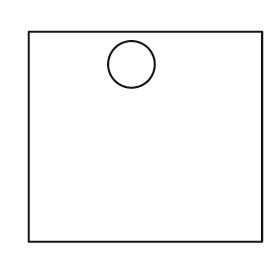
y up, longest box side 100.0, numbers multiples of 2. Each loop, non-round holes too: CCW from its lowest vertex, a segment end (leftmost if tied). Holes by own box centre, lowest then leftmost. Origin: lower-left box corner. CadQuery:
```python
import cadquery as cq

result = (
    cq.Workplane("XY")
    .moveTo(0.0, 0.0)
    .lineTo(100.0, 0.0)
    .lineTo(100.0, 90.0)
    .lineTo(0.0, 90.0)
    .close()
    .moveTo(44.0, 76.0)
    .circle(10.0)
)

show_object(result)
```